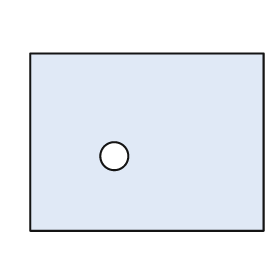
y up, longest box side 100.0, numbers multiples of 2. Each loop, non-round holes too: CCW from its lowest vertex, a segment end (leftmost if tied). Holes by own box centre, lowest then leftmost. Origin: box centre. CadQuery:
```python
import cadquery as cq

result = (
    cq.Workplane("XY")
    .moveTo(-50.0, -38.0)
    .lineTo(50.0, -38.0)
    .lineTo(50.0, 38.0)
    .lineTo(-50.0, 38.0)
    .close()
    .moveTo(-14.0, -6.0)
    .circle(6.0)
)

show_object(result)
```